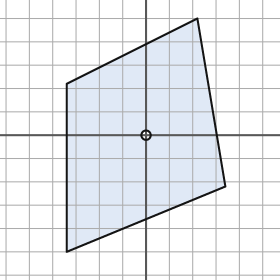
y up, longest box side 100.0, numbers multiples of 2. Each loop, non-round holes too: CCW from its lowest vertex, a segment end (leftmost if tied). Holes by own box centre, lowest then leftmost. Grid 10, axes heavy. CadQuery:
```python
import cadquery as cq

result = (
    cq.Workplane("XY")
    .moveTo(-34.0, -50.0)
    .lineTo(34.0, -22.0)
    .lineTo(22.0, 50.0)
    .lineTo(-34.0, 22.0)
    .close()
    .moveTo(0.0, 0.0)
    .circle(2.0)
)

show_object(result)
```